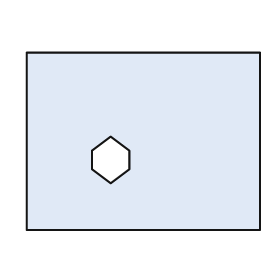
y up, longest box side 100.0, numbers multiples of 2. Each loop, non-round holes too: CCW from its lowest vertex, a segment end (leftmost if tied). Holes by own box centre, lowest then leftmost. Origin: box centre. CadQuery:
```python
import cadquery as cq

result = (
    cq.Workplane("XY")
    .moveTo(-50.0, -38.0)
    .lineTo(50.0, -38.0)
    .lineTo(50.0, 38.0)
    .lineTo(-50.0, 38.0)
    .close()
    .moveTo(-14.0, -18.0)
    .lineTo(-6.0, -12.0)
    .lineTo(-6.0, -4.0)
    .lineTo(-14.0, 2.0)
    .lineTo(-22.0, -4.0)
    .lineTo(-22.0, -12.0)
    .close()
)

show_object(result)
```